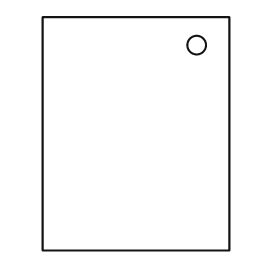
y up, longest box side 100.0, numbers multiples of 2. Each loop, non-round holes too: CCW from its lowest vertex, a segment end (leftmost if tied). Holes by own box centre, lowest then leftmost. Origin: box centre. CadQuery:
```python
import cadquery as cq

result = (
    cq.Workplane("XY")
    .moveTo(-40.0, -50.0)
    .lineTo(40.0, -50.0)
    .lineTo(40.0, 50.0)
    .lineTo(-40.0, 50.0)
    .close()
    .moveTo(26.0, 38.0)
    .circle(4.0)
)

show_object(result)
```